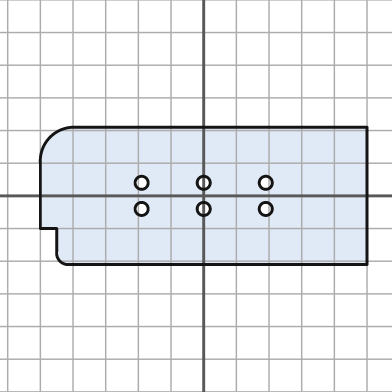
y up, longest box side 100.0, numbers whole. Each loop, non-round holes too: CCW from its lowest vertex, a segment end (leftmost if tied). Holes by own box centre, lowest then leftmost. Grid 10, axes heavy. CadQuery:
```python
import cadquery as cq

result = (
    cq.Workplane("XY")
    .moveTo(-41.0, -21.0)
    .lineTo(50.0, -21.0)
    .lineTo(50.0, 21.0)
    .lineTo(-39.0, 21.0)
    .threePointArc((-47.0, 18.0), (-50.0, 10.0))
    .lineTo(-50.0, -10.0)
    .lineTo(-45.0, -10.0)
    .lineTo(-45.0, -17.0)
    .threePointArc((-44.0, -20.0), (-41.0, -21.0))
    .close()
    .moveTo(-19.0, -4.0)
    .circle(2.0)
    .moveTo(0.0, -4.0)
    .circle(2.0)
    .moveTo(19.0, -4.0)
    .circle(2.0)
    .moveTo(-19.0, 4.0)
    .circle(2.0)
    .moveTo(0.0, 4.0)
    .circle(2.0)
    .moveTo(19.0, 4.0)
    .circle(2.0)
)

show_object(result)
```